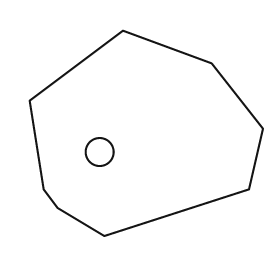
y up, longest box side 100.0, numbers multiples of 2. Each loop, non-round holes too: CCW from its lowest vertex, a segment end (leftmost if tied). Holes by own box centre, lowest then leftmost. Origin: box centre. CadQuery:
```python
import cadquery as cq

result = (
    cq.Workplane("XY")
    .moveTo(-18.0, -44.0)
    .lineTo(44.0, -24.0)
    .lineTo(50.0, 2.0)
    .lineTo(28.0, 30.0)
    .lineTo(-10.0, 44.0)
    .lineTo(-50.0, 14.0)
    .lineTo(-44.0, -24.0)
    .lineTo(-38.0, -32.0)
    .close()
    .moveTo(-20.0, -8.0)
    .circle(6.0)
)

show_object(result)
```